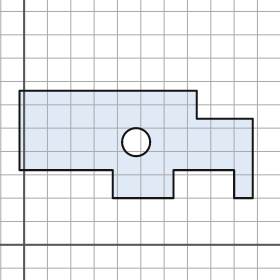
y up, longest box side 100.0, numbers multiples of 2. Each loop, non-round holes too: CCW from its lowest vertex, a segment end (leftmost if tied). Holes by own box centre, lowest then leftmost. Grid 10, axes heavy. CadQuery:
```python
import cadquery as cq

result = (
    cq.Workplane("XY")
    .moveTo(38.0, 20.0)
    .lineTo(64.0, 20.0)
    .lineTo(64.0, 32.0)
    .lineTo(90.0, 32.0)
    .lineTo(90.0, 20.0)
    .lineTo(98.0, 20.0)
    .lineTo(98.0, 54.0)
    .lineTo(74.0, 54.0)
    .lineTo(74.0, 66.0)
    .lineTo(-2.0, 66.0)
    .lineTo(-2.0, 32.0)
    .lineTo(38.0, 32.0)
    .close()
    .moveTo(48.0, 44.0)
    .circle(6.0)
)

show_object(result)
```